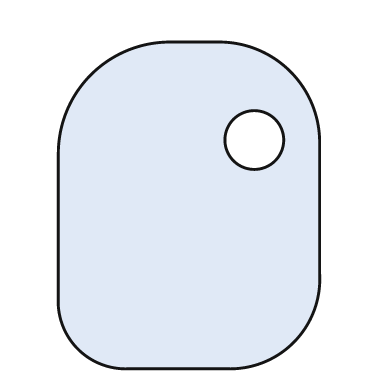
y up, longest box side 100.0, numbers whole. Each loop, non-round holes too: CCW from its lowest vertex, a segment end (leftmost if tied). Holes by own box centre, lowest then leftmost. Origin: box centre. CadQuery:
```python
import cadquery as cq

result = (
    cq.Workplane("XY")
    .moveTo(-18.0, -50.0)
    .lineTo(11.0, -50.0)
    .threePointArc((32.0, -42.0), (40.0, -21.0))
    .lineTo(40.0, 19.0)
    .threePointArc((31.0, 41.0), (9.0, 50.0))
    .lineTo(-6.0, 50.0)
    .threePointArc((-30.0, 40.0), (-40.0, 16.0))
    .lineTo(-40.0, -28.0)
    .threePointArc((-34.0, -44.0), (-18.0, -50.0))
    .close()
    .moveTo(20.0, 20.0)
    .circle(9.0)
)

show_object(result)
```